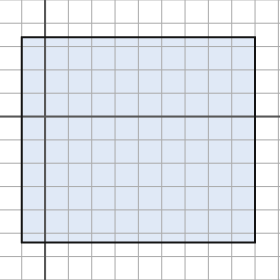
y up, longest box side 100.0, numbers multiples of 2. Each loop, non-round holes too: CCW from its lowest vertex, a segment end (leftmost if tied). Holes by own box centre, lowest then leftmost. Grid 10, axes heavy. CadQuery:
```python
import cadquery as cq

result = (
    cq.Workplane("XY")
    .moveTo(-10.0, -54.0)
    .lineTo(90.0, -54.0)
    .lineTo(90.0, 34.0)
    .lineTo(-10.0, 34.0)
    .close()
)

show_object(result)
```